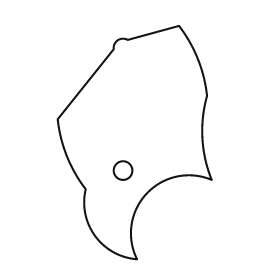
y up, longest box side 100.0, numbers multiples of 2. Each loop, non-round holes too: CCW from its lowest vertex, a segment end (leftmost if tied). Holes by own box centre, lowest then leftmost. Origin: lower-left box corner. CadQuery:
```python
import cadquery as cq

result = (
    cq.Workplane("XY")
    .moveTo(34.0, 0.0)
    .threePointArc((38.0, 28.0), (66.0, 34.0))
    .threePointArc((62.0, 52.0), (64.0, 70.0))
    .threePointArc((60.0, 86.0), (52.0, 100.0))
    .lineTo(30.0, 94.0)
    .threePointArc((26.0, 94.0), (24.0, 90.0))
    .lineTo(0.0, 60.0)
    .threePointArc((4.0, 44.0), (12.0, 30.0))
    .threePointArc((16.0, 10.0), (34.0, 0.0))
    .close()
    .moveTo(28.0, 38.0)
    .circle(4.0)
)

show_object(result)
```